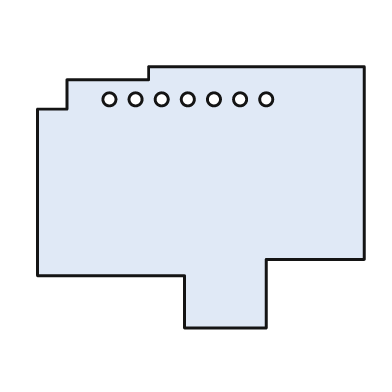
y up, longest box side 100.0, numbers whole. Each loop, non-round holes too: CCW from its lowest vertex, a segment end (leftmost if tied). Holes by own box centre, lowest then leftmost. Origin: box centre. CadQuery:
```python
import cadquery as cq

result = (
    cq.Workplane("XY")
    .moveTo(-5.0, -40.0)
    .lineTo(20.0, -40.0)
    .lineTo(20.0, -19.0)
    .lineTo(50.0, -19.0)
    .lineTo(50.0, 40.0)
    .lineTo(-16.0, 40.0)
    .lineTo(-16.0, 36.0)
    .lineTo(-41.0, 36.0)
    .lineTo(-41.0, 27.0)
    .lineTo(-50.0, 27.0)
    .lineTo(-50.0, -24.0)
    .lineTo(-5.0, -24.0)
    .close()
    .moveTo(-28.0, 30.0)
    .circle(2.0)
    .moveTo(-20.0, 30.0)
    .circle(2.0)
    .moveTo(-12.0, 30.0)
    .circle(2.0)
    .moveTo(-4.0, 30.0)
    .circle(2.0)
    .moveTo(4.0, 30.0)
    .circle(2.0)
    .moveTo(12.0, 30.0)
    .circle(2.0)
    .moveTo(20.0, 30.0)
    .circle(2.0)
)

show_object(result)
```